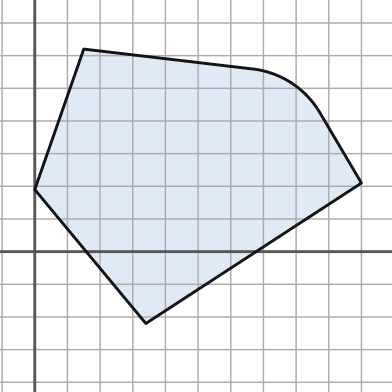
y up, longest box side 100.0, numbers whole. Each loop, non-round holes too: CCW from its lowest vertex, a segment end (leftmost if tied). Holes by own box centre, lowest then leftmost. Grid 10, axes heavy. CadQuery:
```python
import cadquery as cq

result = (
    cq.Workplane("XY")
    .moveTo(34.0, -22.0)
    .lineTo(100.0, 21.0)
    .lineTo(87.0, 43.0)
    .threePointArc((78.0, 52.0), (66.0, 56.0))
    .lineTo(15.0, 62.0)
    .lineTo(0.0, 19.0)
    .close()
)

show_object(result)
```